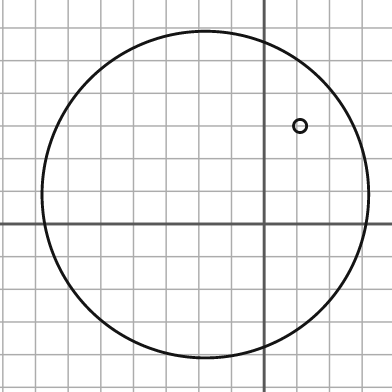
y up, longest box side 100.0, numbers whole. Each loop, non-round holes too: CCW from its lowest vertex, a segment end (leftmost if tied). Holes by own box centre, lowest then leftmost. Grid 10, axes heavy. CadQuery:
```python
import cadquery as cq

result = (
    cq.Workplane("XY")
    .moveTo(-18.0, 9.0)
    .circle(50.0)
    .moveTo(11.0, 30.0)
    .circle(2.0)
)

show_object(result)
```